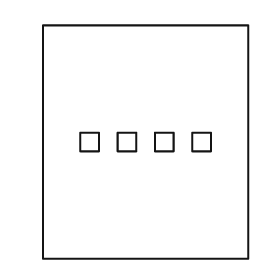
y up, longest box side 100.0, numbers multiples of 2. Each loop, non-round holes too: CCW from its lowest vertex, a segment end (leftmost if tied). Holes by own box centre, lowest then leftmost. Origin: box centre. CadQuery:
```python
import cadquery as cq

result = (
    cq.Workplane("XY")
    .moveTo(-44.0, -50.0)
    .lineTo(44.0, -50.0)
    .lineTo(44.0, 50.0)
    .lineTo(-44.0, 50.0)
    .close()
    .moveTo(-28.0, -4.0)
    .lineTo(-20.0, -4.0)
    .lineTo(-20.0, 4.0)
    .lineTo(-28.0, 4.0)
    .close()
    .moveTo(-12.0, -4.0)
    .lineTo(-4.0, -4.0)
    .lineTo(-4.0, 4.0)
    .lineTo(-12.0, 4.0)
    .close()
    .moveTo(4.0, -4.0)
    .lineTo(12.0, -4.0)
    .lineTo(12.0, 4.0)
    .lineTo(4.0, 4.0)
    .close()
    .moveTo(20.0, -4.0)
    .lineTo(28.0, -4.0)
    .lineTo(28.0, 4.0)
    .lineTo(20.0, 4.0)
    .close()
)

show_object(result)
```